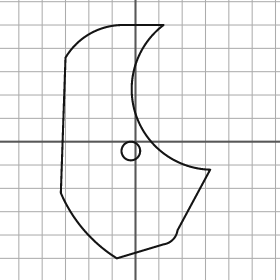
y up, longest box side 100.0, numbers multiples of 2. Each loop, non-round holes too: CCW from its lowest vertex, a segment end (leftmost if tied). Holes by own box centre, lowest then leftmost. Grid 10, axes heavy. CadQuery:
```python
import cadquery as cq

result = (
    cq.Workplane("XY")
    .moveTo(-8.0, -50.0)
    .lineTo(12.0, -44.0)
    .threePointArc((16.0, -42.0), (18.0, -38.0))
    .lineTo(32.0, -12.0)
    .threePointArc((0.0, 12.0), (12.0, 50.0))
    .lineTo(-6.0, 50.0)
    .threePointArc((-20.0, 46.0), (-30.0, 36.0))
    .lineTo(-32.0, -22.0)
    .threePointArc((-22.0, -38.0), (-8.0, -50.0))
    .close()
    .moveTo(-2.0, -4.0)
    .circle(4.0)
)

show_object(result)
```